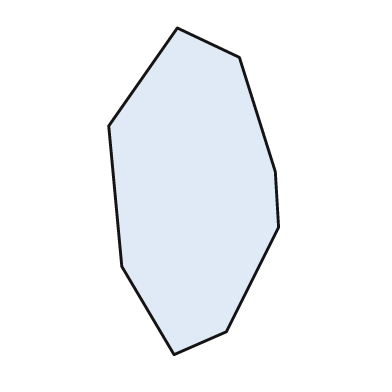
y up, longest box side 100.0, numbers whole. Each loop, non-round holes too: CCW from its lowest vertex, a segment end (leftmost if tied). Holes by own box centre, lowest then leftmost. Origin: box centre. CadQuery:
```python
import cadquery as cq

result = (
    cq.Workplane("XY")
    .moveTo(-6.0, -50.0)
    .lineTo(10.0, -43.0)
    .lineTo(26.0, -11.0)
    .lineTo(25.0, 6.0)
    .lineTo(14.0, 41.0)
    .lineTo(-5.0, 50.0)
    .lineTo(-26.0, 20.0)
    .lineTo(-22.0, -23.0)
    .close()
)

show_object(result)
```